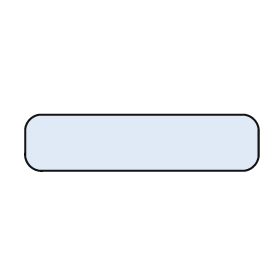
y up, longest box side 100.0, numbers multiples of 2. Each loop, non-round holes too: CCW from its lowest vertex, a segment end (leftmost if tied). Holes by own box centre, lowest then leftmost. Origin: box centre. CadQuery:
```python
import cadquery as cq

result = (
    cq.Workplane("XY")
    .moveTo(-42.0, -12.0)
    .lineTo(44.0, -12.0)
    .threePointArc((48.0, -10.0), (50.0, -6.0))
    .lineTo(50.0, 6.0)
    .threePointArc((48.0, 10.0), (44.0, 12.0))
    .lineTo(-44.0, 12.0)
    .threePointArc((-48.0, 10.0), (-50.0, 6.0))
    .lineTo(-50.0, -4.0)
    .threePointArc((-48.0, -10.0), (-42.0, -12.0))
    .close()
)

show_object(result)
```